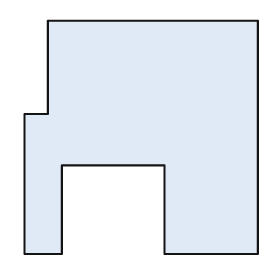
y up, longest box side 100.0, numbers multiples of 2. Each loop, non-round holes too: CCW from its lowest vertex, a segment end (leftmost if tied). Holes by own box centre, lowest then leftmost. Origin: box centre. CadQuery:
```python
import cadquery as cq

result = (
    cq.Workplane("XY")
    .moveTo(-50.0, -50.0)
    .lineTo(-34.0, -50.0)
    .lineTo(-34.0, -12.0)
    .lineTo(10.0, -12.0)
    .lineTo(10.0, -50.0)
    .lineTo(50.0, -50.0)
    .lineTo(50.0, 50.0)
    .lineTo(-40.0, 50.0)
    .lineTo(-40.0, 10.0)
    .lineTo(-50.0, 10.0)
    .close()
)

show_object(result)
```